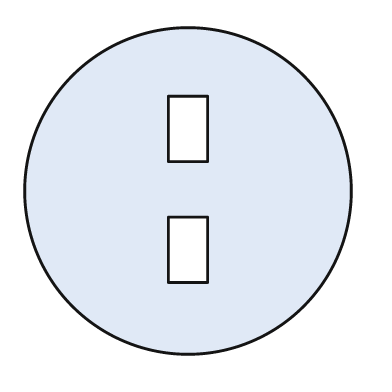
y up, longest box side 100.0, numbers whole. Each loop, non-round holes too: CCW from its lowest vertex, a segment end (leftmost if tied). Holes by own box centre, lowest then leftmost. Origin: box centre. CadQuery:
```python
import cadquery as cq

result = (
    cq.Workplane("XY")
    .moveTo(0.0, 0.0)
    .circle(50.0)
    .moveTo(-6.0, -28.0)
    .lineTo(6.0, -28.0)
    .lineTo(6.0, -8.0)
    .lineTo(-6.0, -8.0)
    .close()
    .moveTo(-6.0, 9.0)
    .lineTo(6.0, 9.0)
    .lineTo(6.0, 29.0)
    .lineTo(-6.0, 29.0)
    .close()
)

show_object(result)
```